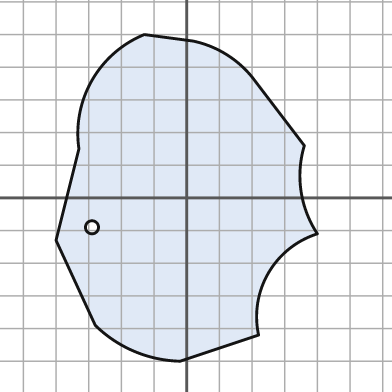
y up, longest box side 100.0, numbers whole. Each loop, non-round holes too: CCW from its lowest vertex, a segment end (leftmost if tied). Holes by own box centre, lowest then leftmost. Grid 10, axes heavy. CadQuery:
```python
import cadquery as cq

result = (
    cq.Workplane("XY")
    .moveTo(-2.0, -50.0)
    .lineTo(22.0, -42.0)
    .threePointArc((25.0, -23.0), (40.0, -11.0))
    .threePointArc((35.0, 2.0), (36.0, 16.0))
    .lineTo(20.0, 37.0)
    .threePointArc((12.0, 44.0), (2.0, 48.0))
    .lineTo(-13.0, 50.0)
    .threePointArc((-29.0, 36.0), (-33.0, 15.0))
    .lineTo(-40.0, -13.0)
    .lineTo(-28.0, -39.0)
    .threePointArc((-16.0, -47.0), (-2.0, -50.0))
    .close()
    .moveTo(-29.0, -9.0)
    .circle(2.0)
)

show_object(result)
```